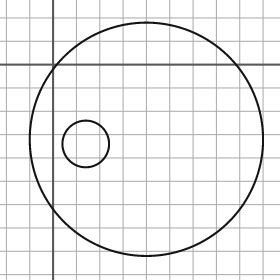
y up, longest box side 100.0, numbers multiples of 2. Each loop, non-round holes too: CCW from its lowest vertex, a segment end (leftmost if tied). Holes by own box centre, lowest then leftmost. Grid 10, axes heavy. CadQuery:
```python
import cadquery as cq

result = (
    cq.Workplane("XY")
    .moveTo(40.0, -32.0)
    .circle(50.0)
    .moveTo(14.0, -34.0)
    .circle(10.0)
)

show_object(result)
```